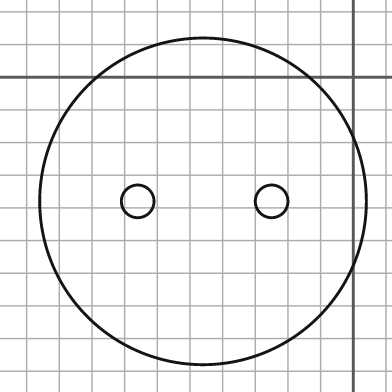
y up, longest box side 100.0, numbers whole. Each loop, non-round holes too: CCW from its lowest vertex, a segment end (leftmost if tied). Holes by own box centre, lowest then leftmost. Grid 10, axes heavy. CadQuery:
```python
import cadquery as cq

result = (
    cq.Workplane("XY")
    .moveTo(-46.0, -38.0)
    .circle(50.0)
    .moveTo(-66.0, -38.0)
    .circle(5.0)
    .moveTo(-25.0, -38.0)
    .circle(5.0)
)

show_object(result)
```